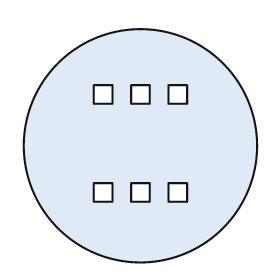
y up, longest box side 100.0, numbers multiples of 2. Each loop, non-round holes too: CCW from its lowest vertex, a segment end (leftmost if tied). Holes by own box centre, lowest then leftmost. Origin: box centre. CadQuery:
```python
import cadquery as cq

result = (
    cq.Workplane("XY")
    .moveTo(0.0, 0.0)
    .circle(50.0)
    .moveTo(-20.0, -24.0)
    .lineTo(-12.0, -24.0)
    .lineTo(-12.0, -16.0)
    .lineTo(-20.0, -16.0)
    .close()
    .moveTo(-4.0, -24.0)
    .lineTo(4.0, -24.0)
    .lineTo(4.0, -16.0)
    .lineTo(-4.0, -16.0)
    .close()
    .moveTo(12.0, -24.0)
    .lineTo(20.0, -24.0)
    .lineTo(20.0, -16.0)
    .lineTo(12.0, -16.0)
    .close()
    .moveTo(-20.0, 18.0)
    .lineTo(-12.0, 18.0)
    .lineTo(-12.0, 26.0)
    .lineTo(-20.0, 26.0)
    .close()
    .moveTo(-4.0, 18.0)
    .lineTo(4.0, 18.0)
    .lineTo(4.0, 26.0)
    .lineTo(-4.0, 26.0)
    .close()
    .moveTo(12.0, 18.0)
    .lineTo(20.0, 18.0)
    .lineTo(20.0, 26.0)
    .lineTo(12.0, 26.0)
    .close()
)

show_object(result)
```